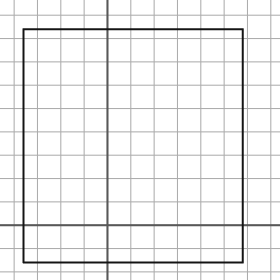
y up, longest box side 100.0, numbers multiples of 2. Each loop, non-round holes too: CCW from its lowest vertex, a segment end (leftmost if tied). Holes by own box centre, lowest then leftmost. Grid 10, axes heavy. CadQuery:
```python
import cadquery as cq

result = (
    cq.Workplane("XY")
    .moveTo(-36.0, -16.0)
    .lineTo(58.0, -16.0)
    .lineTo(58.0, 84.0)
    .lineTo(-36.0, 84.0)
    .close()
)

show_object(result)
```